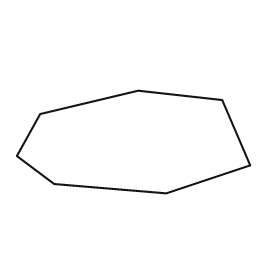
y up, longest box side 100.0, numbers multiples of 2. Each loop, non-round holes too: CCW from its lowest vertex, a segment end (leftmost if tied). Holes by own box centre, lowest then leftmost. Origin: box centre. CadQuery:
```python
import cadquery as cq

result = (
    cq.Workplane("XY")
    .moveTo(14.0, -22.0)
    .lineTo(50.0, -10.0)
    .lineTo(38.0, 18.0)
    .lineTo(2.0, 22.0)
    .lineTo(-40.0, 12.0)
    .lineTo(-50.0, -6.0)
    .lineTo(-34.0, -18.0)
    .close()
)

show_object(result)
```